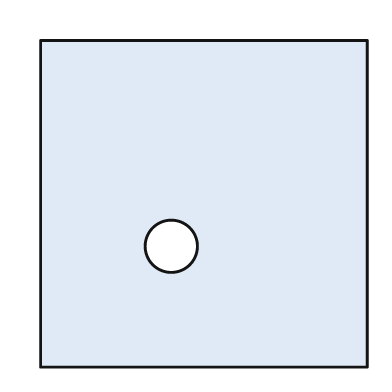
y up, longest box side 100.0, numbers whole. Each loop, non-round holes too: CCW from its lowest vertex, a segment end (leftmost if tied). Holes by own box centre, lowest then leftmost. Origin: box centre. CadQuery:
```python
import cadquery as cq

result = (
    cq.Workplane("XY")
    .moveTo(-50.0, -50.0)
    .lineTo(50.0, -50.0)
    .lineTo(50.0, 50.0)
    .lineTo(-50.0, 50.0)
    .close()
    .moveTo(-10.0, -13.0)
    .circle(8.0)
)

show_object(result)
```